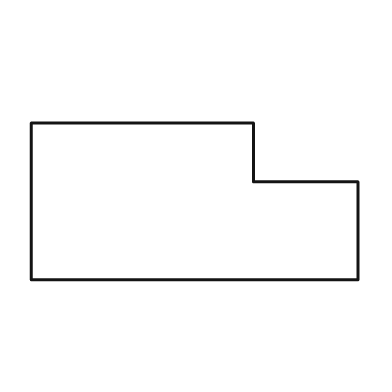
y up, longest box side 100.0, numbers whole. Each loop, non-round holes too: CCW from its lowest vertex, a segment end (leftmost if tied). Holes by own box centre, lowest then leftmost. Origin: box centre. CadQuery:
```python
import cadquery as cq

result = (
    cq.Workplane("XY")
    .moveTo(-50.0, -24.0)
    .lineTo(50.0, -24.0)
    .lineTo(50.0, 6.0)
    .lineTo(18.0, 6.0)
    .lineTo(18.0, 24.0)
    .lineTo(-50.0, 24.0)
    .close()
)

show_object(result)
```